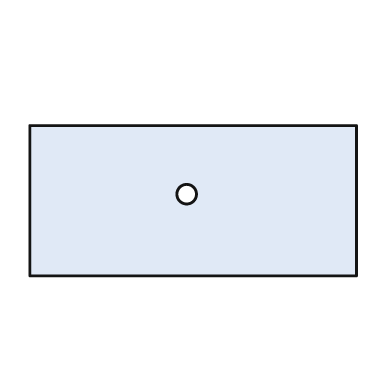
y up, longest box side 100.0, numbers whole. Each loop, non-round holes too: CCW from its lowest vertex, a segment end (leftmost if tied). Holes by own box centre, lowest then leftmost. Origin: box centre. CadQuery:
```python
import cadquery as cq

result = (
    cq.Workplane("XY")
    .moveTo(-50.0, -23.0)
    .lineTo(50.0, -23.0)
    .lineTo(50.0, 23.0)
    .lineTo(-50.0, 23.0)
    .close()
    .moveTo(-2.0, 2.0)
    .circle(3.0)
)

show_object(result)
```